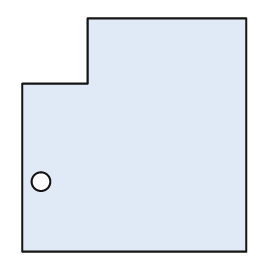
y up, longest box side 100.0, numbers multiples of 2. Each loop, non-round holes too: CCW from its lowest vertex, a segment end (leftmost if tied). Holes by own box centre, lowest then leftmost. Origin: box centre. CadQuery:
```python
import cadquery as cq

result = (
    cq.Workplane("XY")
    .moveTo(-48.0, -50.0)
    .lineTo(48.0, -50.0)
    .lineTo(48.0, 50.0)
    .lineTo(-20.0, 50.0)
    .lineTo(-20.0, 22.0)
    .lineTo(-48.0, 22.0)
    .close()
    .moveTo(-40.0, -20.0)
    .circle(4.0)
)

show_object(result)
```